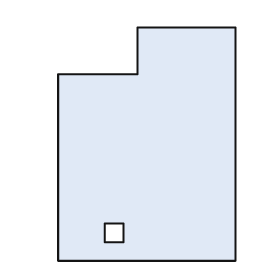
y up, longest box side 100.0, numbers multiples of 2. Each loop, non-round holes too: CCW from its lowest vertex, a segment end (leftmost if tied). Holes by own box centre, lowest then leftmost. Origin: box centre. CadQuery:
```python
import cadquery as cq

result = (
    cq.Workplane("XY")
    .moveTo(-38.0, -50.0)
    .lineTo(38.0, -50.0)
    .lineTo(38.0, 50.0)
    .lineTo(-4.0, 50.0)
    .lineTo(-4.0, 30.0)
    .lineTo(-38.0, 30.0)
    .close()
    .moveTo(-18.0, -42.0)
    .lineTo(-10.0, -42.0)
    .lineTo(-10.0, -34.0)
    .lineTo(-18.0, -34.0)
    .close()
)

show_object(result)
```